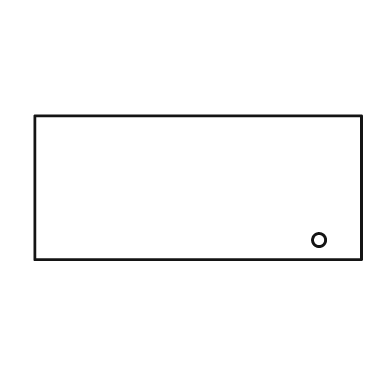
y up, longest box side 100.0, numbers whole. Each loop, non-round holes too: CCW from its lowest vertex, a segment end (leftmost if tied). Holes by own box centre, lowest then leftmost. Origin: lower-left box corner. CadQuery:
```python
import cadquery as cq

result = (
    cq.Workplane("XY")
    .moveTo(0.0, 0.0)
    .lineTo(100.0, 0.0)
    .lineTo(100.0, 44.0)
    .lineTo(0.0, 44.0)
    .close()
    .moveTo(87.0, 6.0)
    .circle(2.0)
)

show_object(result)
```